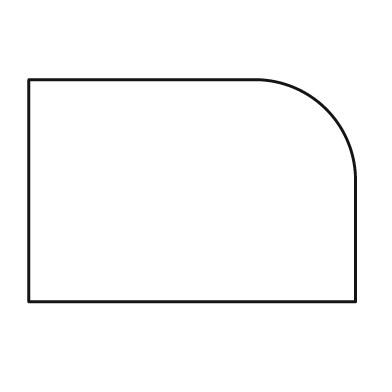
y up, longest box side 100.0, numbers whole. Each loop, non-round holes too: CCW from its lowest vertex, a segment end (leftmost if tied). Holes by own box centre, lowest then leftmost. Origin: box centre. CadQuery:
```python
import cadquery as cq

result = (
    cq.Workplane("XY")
    .moveTo(-50.0, -34.0)
    .lineTo(50.0, -34.0)
    .lineTo(50.0, 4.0)
    .threePointArc((41.0, 25.0), (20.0, 34.0))
    .lineTo(-50.0, 34.0)
    .close()
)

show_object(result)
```